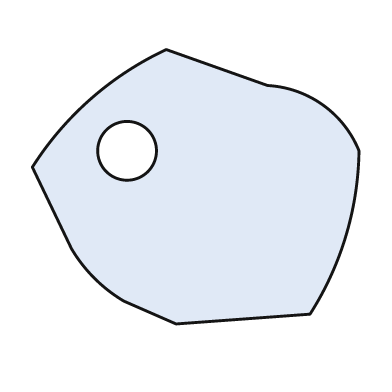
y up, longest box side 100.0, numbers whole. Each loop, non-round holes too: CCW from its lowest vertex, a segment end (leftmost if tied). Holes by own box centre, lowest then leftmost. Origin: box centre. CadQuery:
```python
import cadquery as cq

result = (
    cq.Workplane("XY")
    .moveTo(-6.0, -42.0)
    .lineTo(35.0, -39.0)
    .threePointArc((46.0, -15.0), (50.0, 11.0))
    .threePointArc((39.0, 25.0), (22.0, 31.0))
    .lineTo(-9.0, 42.0)
    .threePointArc((-32.0, 27.0), (-50.0, 6.0))
    .lineTo(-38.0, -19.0)
    .threePointArc((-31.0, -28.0), (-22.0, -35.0))
    .close()
    .moveTo(-21.0, 11.0)
    .circle(9.0)
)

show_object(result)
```